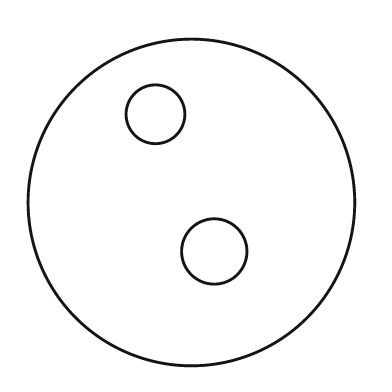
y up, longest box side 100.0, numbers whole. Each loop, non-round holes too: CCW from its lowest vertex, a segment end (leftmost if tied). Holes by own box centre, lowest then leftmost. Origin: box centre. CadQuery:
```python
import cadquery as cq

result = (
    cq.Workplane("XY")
    .moveTo(0.0, 0.0)
    .circle(50.0)
    .moveTo(7.0, -15.0)
    .circle(10.0)
    .moveTo(-11.0, 27.0)
    .circle(9.0)
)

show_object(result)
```